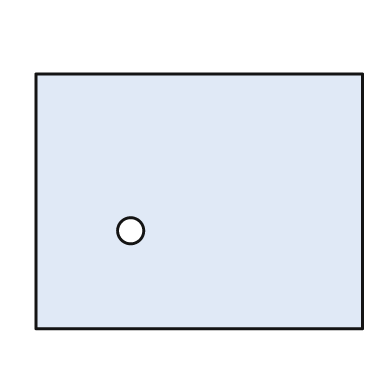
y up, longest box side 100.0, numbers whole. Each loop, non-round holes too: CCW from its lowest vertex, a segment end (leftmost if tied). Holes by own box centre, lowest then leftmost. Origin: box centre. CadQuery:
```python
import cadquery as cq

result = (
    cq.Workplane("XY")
    .moveTo(-50.0, -39.0)
    .lineTo(50.0, -39.0)
    .lineTo(50.0, 39.0)
    .lineTo(-50.0, 39.0)
    .close()
    .moveTo(-21.0, -9.0)
    .circle(4.0)
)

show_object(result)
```